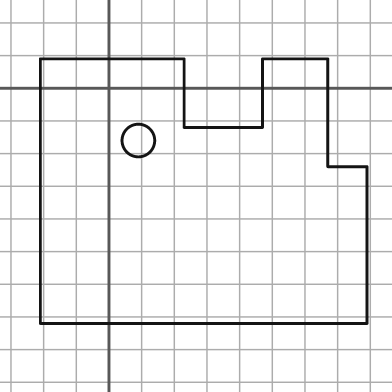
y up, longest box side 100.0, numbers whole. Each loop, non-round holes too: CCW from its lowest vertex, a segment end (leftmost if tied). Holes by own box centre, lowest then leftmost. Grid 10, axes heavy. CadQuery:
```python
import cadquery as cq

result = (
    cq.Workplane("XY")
    .moveTo(-21.0, -72.0)
    .lineTo(79.0, -72.0)
    .lineTo(79.0, -24.0)
    .lineTo(67.0, -24.0)
    .lineTo(67.0, 9.0)
    .lineTo(47.0, 9.0)
    .lineTo(47.0, -12.0)
    .lineTo(23.0, -12.0)
    .lineTo(23.0, 9.0)
    .lineTo(-21.0, 9.0)
    .close()
    .moveTo(9.0, -16.0)
    .circle(5.0)
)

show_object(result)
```